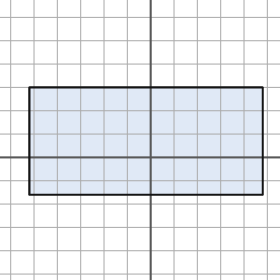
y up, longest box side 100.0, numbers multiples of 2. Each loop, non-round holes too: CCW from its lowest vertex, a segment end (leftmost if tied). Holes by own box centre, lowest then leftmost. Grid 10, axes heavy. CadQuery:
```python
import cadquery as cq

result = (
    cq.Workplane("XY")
    .moveTo(-52.0, -16.0)
    .lineTo(48.0, -16.0)
    .lineTo(48.0, 30.0)
    .lineTo(-52.0, 30.0)
    .close()
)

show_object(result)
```